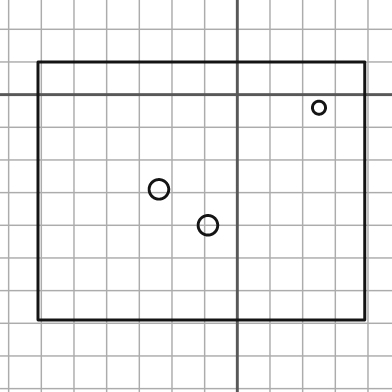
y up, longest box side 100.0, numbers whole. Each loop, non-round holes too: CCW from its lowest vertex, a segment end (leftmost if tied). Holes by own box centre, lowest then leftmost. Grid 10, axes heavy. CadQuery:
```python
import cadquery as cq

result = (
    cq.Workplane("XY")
    .moveTo(-61.0, -69.0)
    .lineTo(39.0, -69.0)
    .lineTo(39.0, 10.0)
    .lineTo(-61.0, 10.0)
    .close()
    .moveTo(-9.0, -40.0)
    .circle(3.0)
    .moveTo(-24.0, -29.0)
    .circle(3.0)
    .moveTo(25.0, -4.0)
    .circle(2.0)
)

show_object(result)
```